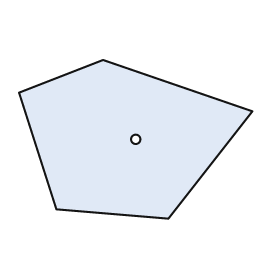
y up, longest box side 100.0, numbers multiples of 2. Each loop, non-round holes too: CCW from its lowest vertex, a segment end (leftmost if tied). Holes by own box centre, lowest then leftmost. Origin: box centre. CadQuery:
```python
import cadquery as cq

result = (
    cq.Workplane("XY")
    .moveTo(14.0, -34.0)
    .lineTo(50.0, 12.0)
    .lineTo(-14.0, 34.0)
    .lineTo(-50.0, 20.0)
    .lineTo(-34.0, -30.0)
    .close()
    .moveTo(0.0, 0.0)
    .circle(2.0)
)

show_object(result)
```